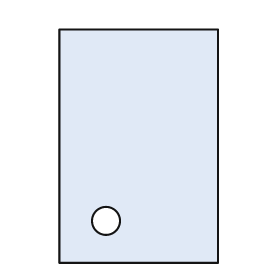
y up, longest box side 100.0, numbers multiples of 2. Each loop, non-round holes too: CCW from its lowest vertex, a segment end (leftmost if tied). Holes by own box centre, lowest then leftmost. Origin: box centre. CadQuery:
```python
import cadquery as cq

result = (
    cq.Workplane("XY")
    .moveTo(-34.0, -50.0)
    .lineTo(34.0, -50.0)
    .lineTo(34.0, 50.0)
    .lineTo(-34.0, 50.0)
    .close()
    .moveTo(-14.0, -32.0)
    .circle(6.0)
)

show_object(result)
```